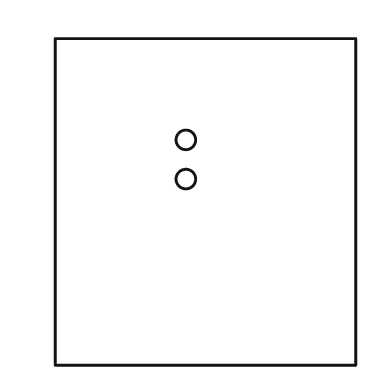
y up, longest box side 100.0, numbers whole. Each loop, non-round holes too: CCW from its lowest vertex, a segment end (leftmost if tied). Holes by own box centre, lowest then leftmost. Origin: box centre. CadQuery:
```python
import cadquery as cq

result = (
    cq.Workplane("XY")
    .moveTo(-46.0, -50.0)
    .lineTo(46.0, -50.0)
    .lineTo(46.0, 50.0)
    .lineTo(-46.0, 50.0)
    .close()
    .moveTo(-6.0, 7.0)
    .circle(3.0)
    .moveTo(-6.0, 19.0)
    .circle(3.0)
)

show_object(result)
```